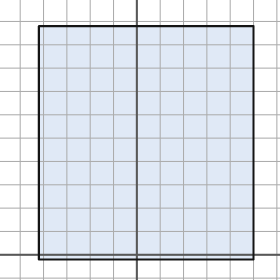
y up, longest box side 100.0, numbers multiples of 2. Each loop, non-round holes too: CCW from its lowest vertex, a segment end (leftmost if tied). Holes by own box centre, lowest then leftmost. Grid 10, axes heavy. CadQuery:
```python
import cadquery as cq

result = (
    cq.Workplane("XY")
    .moveTo(-42.0, -2.0)
    .lineTo(50.0, -2.0)
    .lineTo(50.0, 98.0)
    .lineTo(-42.0, 98.0)
    .close()
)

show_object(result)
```